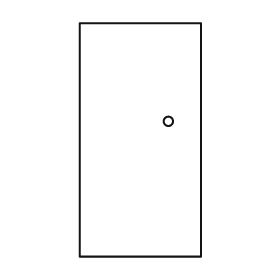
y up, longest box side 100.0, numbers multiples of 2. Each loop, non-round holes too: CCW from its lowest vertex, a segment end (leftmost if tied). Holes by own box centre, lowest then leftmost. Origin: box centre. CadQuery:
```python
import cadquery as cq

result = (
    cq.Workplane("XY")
    .moveTo(-26.0, -50.0)
    .lineTo(26.0, -50.0)
    .lineTo(26.0, 50.0)
    .lineTo(-26.0, 50.0)
    .close()
    .moveTo(12.0, 8.0)
    .circle(2.0)
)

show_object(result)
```